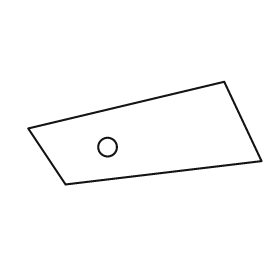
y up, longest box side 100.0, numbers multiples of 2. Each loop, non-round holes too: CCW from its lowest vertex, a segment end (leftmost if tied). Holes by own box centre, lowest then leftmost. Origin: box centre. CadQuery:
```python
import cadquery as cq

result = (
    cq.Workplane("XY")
    .moveTo(-34.0, -22.0)
    .lineTo(50.0, -12.0)
    .lineTo(34.0, 22.0)
    .lineTo(-50.0, 2.0)
    .close()
    .moveTo(-16.0, -6.0)
    .circle(4.0)
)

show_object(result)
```